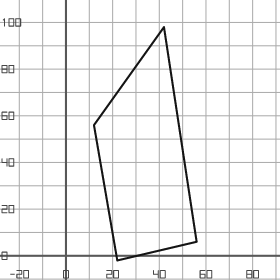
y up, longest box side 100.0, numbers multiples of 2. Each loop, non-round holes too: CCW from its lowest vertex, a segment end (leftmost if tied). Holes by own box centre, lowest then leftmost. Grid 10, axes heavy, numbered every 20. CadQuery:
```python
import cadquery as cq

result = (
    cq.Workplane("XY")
    .moveTo(22.0, -2.0)
    .lineTo(56.0, 6.0)
    .lineTo(42.0, 98.0)
    .lineTo(12.0, 56.0)
    .close()
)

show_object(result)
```